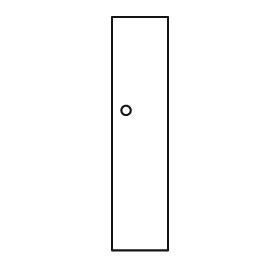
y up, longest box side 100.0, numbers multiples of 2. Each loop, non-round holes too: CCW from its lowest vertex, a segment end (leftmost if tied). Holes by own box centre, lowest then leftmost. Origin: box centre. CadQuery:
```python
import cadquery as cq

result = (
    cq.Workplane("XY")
    .moveTo(-12.0, -50.0)
    .lineTo(12.0, -50.0)
    .lineTo(12.0, 50.0)
    .lineTo(-12.0, 50.0)
    .close()
    .moveTo(-6.0, 10.0)
    .circle(2.0)
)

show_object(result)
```